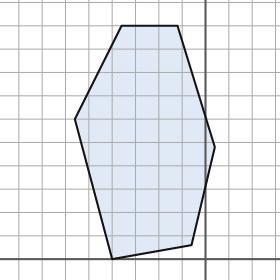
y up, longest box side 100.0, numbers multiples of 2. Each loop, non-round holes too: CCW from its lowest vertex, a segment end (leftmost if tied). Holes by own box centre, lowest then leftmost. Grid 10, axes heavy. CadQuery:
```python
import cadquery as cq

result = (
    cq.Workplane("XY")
    .moveTo(-40.0, 0.0)
    .lineTo(-6.0, 6.0)
    .lineTo(4.0, 48.0)
    .lineTo(-12.0, 100.0)
    .lineTo(-36.0, 100.0)
    .lineTo(-56.0, 60.0)
    .close()
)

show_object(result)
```